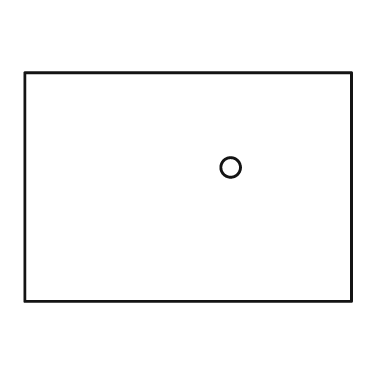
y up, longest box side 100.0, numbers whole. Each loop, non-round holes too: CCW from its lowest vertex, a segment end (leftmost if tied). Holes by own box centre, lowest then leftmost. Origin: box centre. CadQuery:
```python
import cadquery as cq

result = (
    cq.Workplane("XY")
    .moveTo(-50.0, -35.0)
    .lineTo(50.0, -35.0)
    .lineTo(50.0, 35.0)
    .lineTo(-50.0, 35.0)
    .close()
    .moveTo(13.0, 6.0)
    .circle(3.0)
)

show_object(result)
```